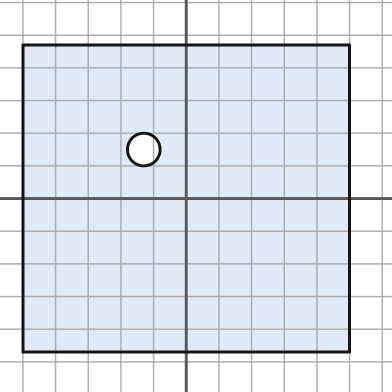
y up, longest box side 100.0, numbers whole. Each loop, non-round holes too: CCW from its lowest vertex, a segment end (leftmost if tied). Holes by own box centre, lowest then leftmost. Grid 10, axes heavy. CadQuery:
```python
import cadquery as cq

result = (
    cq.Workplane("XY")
    .moveTo(-50.0, -47.0)
    .lineTo(50.0, -47.0)
    .lineTo(50.0, 47.0)
    .lineTo(-50.0, 47.0)
    .close()
    .moveTo(-13.0, 15.0)
    .circle(5.0)
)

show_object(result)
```